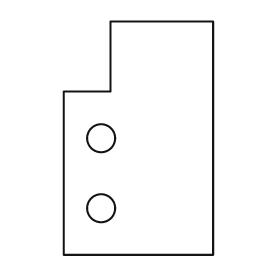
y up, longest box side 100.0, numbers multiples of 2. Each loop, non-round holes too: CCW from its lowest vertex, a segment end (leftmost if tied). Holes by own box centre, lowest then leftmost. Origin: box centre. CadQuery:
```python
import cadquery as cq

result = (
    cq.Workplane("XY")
    .moveTo(-32.0, -50.0)
    .lineTo(32.0, -50.0)
    .lineTo(32.0, 50.0)
    .lineTo(-12.0, 50.0)
    .lineTo(-12.0, 20.0)
    .lineTo(-32.0, 20.0)
    .close()
    .moveTo(-16.0, -30.0)
    .circle(6.0)
    .moveTo(-16.0, 0.0)
    .circle(6.0)
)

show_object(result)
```